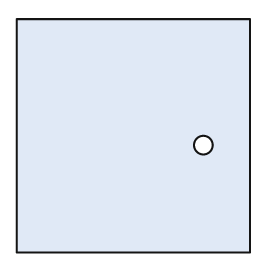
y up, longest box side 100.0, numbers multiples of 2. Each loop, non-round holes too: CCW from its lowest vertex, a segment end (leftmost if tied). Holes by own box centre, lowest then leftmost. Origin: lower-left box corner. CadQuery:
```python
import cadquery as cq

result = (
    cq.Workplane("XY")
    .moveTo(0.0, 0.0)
    .lineTo(100.0, 0.0)
    .lineTo(100.0, 100.0)
    .lineTo(0.0, 100.0)
    .close()
    .moveTo(80.0, 46.0)
    .circle(4.0)
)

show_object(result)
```